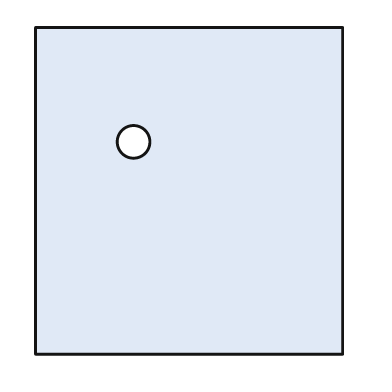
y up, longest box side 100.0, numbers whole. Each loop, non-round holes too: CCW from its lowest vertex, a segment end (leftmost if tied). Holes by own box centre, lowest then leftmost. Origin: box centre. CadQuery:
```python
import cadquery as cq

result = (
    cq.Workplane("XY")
    .moveTo(-47.0, -50.0)
    .lineTo(47.0, -50.0)
    .lineTo(47.0, 50.0)
    .lineTo(-47.0, 50.0)
    .close()
    .moveTo(-17.0, 15.0)
    .circle(5.0)
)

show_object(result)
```